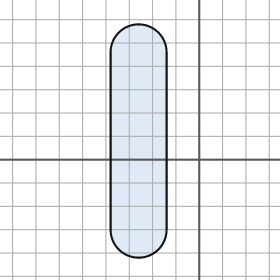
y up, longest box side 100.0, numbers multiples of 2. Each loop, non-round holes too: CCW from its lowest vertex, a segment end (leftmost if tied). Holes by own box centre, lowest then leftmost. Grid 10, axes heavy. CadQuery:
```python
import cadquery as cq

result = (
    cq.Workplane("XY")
    .moveTo(-38.0, -30.0)
    .threePointArc((-26.0, -42.0), (-14.0, -30.0))
    .lineTo(-14.0, 46.0)
    .threePointArc((-26.0, 58.0), (-38.0, 46.0))
    .close()
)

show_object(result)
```